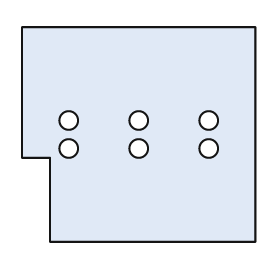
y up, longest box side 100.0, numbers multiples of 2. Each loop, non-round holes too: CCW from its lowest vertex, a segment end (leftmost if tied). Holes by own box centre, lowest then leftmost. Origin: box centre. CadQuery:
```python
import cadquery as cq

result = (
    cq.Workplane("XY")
    .moveTo(-38.0, -46.0)
    .lineTo(50.0, -46.0)
    .lineTo(50.0, 46.0)
    .lineTo(-50.0, 46.0)
    .lineTo(-50.0, -10.0)
    .lineTo(-38.0, -10.0)
    .close()
    .moveTo(-30.0, -6.0)
    .circle(4.0)
    .moveTo(0.0, -6.0)
    .circle(4.0)
    .moveTo(30.0, -6.0)
    .circle(4.0)
    .moveTo(-30.0, 6.0)
    .circle(4.0)
    .moveTo(0.0, 6.0)
    .circle(4.0)
    .moveTo(30.0, 6.0)
    .circle(4.0)
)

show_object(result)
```